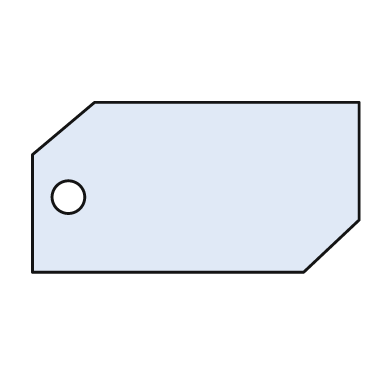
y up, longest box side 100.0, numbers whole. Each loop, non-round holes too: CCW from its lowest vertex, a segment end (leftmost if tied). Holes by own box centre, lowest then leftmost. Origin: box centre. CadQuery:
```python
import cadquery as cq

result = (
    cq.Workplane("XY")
    .moveTo(-50.0, -26.0)
    .lineTo(33.0, -26.0)
    .lineTo(50.0, -10.0)
    .lineTo(50.0, 26.0)
    .lineTo(-31.0, 26.0)
    .lineTo(-50.0, 10.0)
    .close()
    .moveTo(-39.0, -3.0)
    .circle(5.0)
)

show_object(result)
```